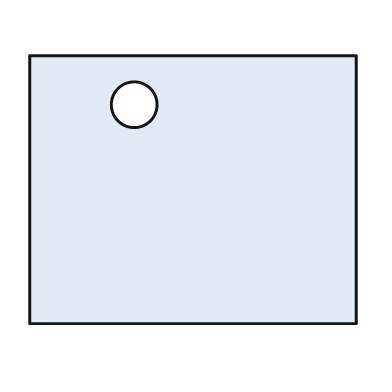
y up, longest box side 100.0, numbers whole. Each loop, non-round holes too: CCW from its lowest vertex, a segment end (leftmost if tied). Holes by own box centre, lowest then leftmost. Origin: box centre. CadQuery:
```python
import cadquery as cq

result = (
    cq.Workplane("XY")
    .moveTo(-50.0, -41.0)
    .lineTo(50.0, -41.0)
    .lineTo(50.0, 41.0)
    .lineTo(-50.0, 41.0)
    .close()
    .moveTo(-18.0, 26.0)
    .circle(7.0)
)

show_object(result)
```